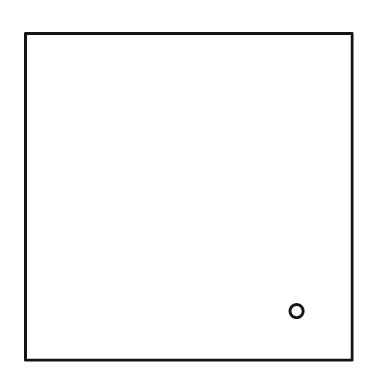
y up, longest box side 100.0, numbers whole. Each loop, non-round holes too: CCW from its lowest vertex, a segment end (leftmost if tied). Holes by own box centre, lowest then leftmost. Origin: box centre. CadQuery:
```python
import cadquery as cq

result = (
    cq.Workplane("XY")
    .moveTo(-50.0, -50.0)
    .lineTo(50.0, -50.0)
    .lineTo(50.0, 50.0)
    .lineTo(-50.0, 50.0)
    .close()
    .moveTo(33.0, -35.0)
    .circle(2.0)
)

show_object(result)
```